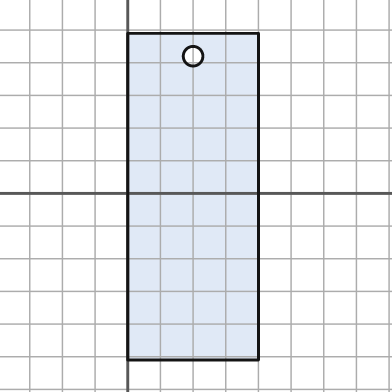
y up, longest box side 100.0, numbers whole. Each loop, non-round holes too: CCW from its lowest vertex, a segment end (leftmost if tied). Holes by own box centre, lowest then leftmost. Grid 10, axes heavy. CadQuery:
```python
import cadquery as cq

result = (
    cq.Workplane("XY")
    .moveTo(0.0, -51.0)
    .lineTo(40.0, -51.0)
    .lineTo(40.0, 49.0)
    .lineTo(0.0, 49.0)
    .close()
    .moveTo(20.0, 42.0)
    .circle(3.0)
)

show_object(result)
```